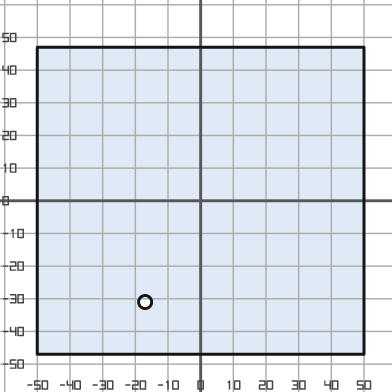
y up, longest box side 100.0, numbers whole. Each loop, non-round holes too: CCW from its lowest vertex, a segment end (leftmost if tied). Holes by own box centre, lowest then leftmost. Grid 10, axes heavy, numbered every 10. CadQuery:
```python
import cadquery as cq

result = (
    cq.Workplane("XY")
    .moveTo(-50.0, -47.0)
    .lineTo(50.0, -47.0)
    .lineTo(50.0, 47.0)
    .lineTo(-50.0, 47.0)
    .close()
    .moveTo(-17.0, -31.0)
    .circle(2.0)
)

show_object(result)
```